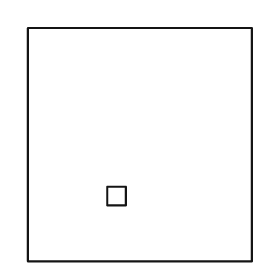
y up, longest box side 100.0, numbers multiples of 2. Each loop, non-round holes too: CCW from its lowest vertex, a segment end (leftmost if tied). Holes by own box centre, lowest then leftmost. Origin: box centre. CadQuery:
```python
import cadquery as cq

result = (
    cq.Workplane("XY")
    .moveTo(-48.0, -50.0)
    .lineTo(48.0, -50.0)
    .lineTo(48.0, 50.0)
    .lineTo(-48.0, 50.0)
    .close()
    .moveTo(-14.0, -26.0)
    .lineTo(-6.0, -26.0)
    .lineTo(-6.0, -18.0)
    .lineTo(-14.0, -18.0)
    .close()
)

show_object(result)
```